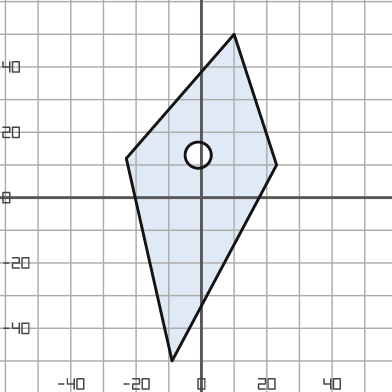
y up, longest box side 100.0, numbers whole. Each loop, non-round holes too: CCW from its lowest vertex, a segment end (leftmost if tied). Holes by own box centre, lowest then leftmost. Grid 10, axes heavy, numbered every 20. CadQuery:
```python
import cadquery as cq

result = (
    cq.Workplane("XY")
    .moveTo(-9.0, -50.0)
    .lineTo(23.0, 10.0)
    .lineTo(10.0, 50.0)
    .lineTo(-23.0, 12.0)
    .close()
    .moveTo(-1.0, 13.0)
    .circle(4.0)
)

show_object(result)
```